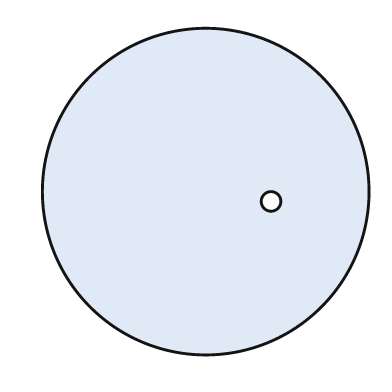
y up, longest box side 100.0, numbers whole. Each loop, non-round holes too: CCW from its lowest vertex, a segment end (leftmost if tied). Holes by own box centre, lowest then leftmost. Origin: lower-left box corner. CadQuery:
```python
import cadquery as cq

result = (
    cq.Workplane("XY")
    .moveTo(50.0, 50.0)
    .circle(50.0)
    .moveTo(70.0, 47.0)
    .circle(3.0)
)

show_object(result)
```